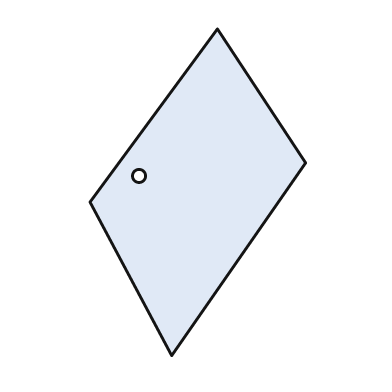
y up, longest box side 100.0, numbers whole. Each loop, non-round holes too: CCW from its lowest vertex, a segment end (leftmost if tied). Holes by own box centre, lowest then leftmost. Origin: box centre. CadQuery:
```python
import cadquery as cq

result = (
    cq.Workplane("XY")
    .moveTo(-8.0, -50.0)
    .lineTo(33.0, 9.0)
    .lineTo(6.0, 50.0)
    .lineTo(-33.0, -3.0)
    .close()
    .moveTo(-18.0, 5.0)
    .circle(2.0)
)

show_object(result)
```